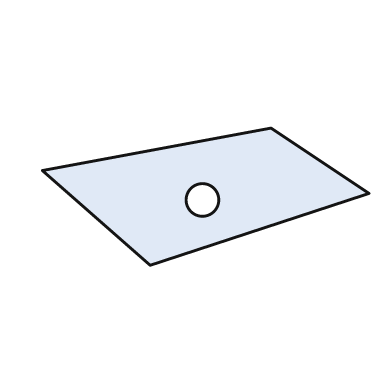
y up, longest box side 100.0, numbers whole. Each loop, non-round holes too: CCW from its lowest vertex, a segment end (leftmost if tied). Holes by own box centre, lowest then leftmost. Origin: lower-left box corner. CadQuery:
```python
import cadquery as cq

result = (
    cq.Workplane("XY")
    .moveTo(33.0, 0.0)
    .lineTo(100.0, 22.0)
    .lineTo(70.0, 42.0)
    .lineTo(0.0, 29.0)
    .close()
    .moveTo(49.0, 20.0)
    .circle(5.0)
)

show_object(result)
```